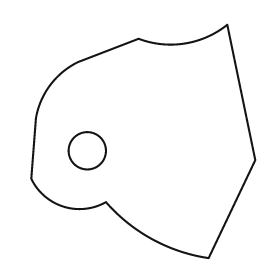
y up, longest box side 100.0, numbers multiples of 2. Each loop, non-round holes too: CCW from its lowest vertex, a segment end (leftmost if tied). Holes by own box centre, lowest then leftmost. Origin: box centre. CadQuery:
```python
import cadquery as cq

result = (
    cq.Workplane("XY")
    .moveTo(28.0, -50.0)
    .lineTo(48.0, -8.0)
    .lineTo(36.0, 50.0)
    .threePointArc((18.0, 42.0), (-2.0, 44.0))
    .lineTo(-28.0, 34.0)
    .threePointArc((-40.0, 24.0), (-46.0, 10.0))
    .lineTo(-48.0, -16.0)
    .threePointArc((-34.0, -28.0), (-16.0, -26.0))
    .threePointArc((4.0, -42.0), (28.0, -50.0))
    .close()
    .moveTo(-24.0, -4.0)
    .circle(8.0)
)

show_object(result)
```